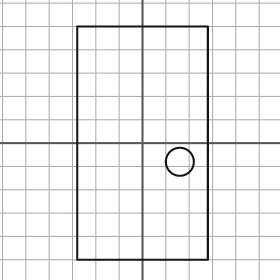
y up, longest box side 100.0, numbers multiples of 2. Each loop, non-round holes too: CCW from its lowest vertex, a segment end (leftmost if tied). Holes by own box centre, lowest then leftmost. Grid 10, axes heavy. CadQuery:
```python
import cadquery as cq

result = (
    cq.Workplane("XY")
    .moveTo(-28.0, -50.0)
    .lineTo(28.0, -50.0)
    .lineTo(28.0, 50.0)
    .lineTo(-28.0, 50.0)
    .close()
    .moveTo(16.0, -8.0)
    .circle(6.0)
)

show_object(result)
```